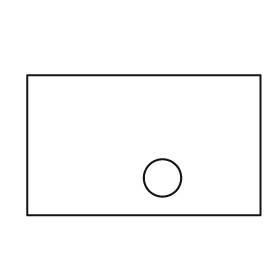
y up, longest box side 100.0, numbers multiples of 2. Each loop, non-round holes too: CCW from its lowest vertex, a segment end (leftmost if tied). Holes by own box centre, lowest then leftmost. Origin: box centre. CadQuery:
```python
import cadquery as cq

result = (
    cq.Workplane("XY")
    .moveTo(-50.0, -30.0)
    .lineTo(50.0, -30.0)
    .lineTo(50.0, 30.0)
    .lineTo(-50.0, 30.0)
    .close()
    .moveTo(8.0, -14.0)
    .circle(8.0)
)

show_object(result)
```